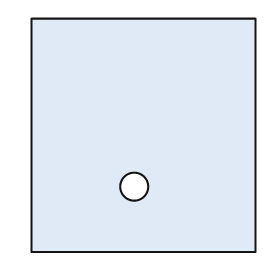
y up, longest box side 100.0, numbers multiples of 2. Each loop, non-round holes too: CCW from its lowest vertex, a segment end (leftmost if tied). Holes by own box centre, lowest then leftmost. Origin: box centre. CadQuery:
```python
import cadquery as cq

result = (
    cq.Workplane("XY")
    .moveTo(-48.0, -50.0)
    .lineTo(48.0, -50.0)
    .lineTo(48.0, 50.0)
    .lineTo(-48.0, 50.0)
    .close()
    .moveTo(-4.0, -22.0)
    .circle(6.0)
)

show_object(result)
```